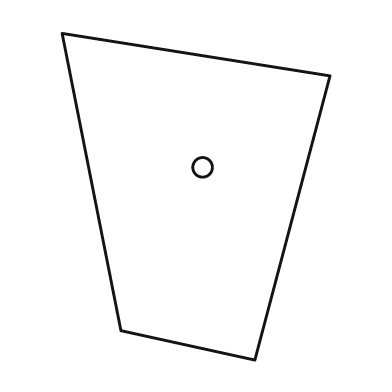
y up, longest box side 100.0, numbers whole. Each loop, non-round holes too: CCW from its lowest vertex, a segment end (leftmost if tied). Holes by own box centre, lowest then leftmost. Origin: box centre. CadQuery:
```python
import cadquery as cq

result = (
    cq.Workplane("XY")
    .moveTo(18.0, -50.0)
    .lineTo(41.0, 37.0)
    .lineTo(-41.0, 50.0)
    .lineTo(-23.0, -41.0)
    .close()
    .moveTo(2.0, 9.0)
    .circle(3.0)
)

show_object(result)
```